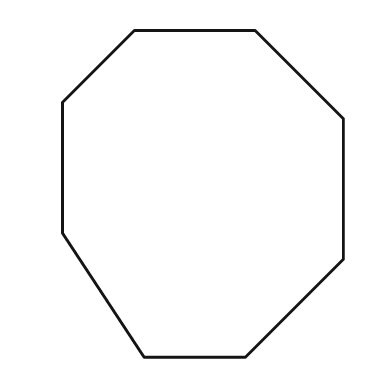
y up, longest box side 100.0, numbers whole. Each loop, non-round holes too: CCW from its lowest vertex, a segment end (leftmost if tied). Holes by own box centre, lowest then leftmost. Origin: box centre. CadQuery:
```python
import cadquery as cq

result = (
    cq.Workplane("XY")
    .moveTo(-18.0, -50.0)
    .lineTo(13.0, -50.0)
    .lineTo(43.0, -20.0)
    .lineTo(43.0, 23.0)
    .lineTo(16.0, 50.0)
    .lineTo(-21.0, 50.0)
    .lineTo(-43.0, 28.0)
    .lineTo(-43.0, -12.0)
    .close()
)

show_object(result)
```